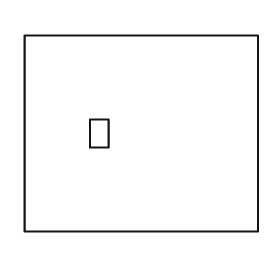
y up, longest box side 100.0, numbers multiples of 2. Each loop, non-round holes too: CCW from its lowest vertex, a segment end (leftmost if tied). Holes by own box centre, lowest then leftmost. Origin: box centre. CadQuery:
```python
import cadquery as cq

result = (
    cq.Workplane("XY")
    .moveTo(-50.0, -42.0)
    .lineTo(50.0, -42.0)
    .lineTo(50.0, 42.0)
    .lineTo(-50.0, 42.0)
    .close()
    .moveTo(-22.0, -6.0)
    .lineTo(-14.0, -6.0)
    .lineTo(-14.0, 6.0)
    .lineTo(-22.0, 6.0)
    .close()
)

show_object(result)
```